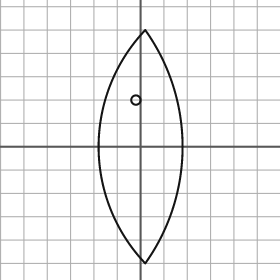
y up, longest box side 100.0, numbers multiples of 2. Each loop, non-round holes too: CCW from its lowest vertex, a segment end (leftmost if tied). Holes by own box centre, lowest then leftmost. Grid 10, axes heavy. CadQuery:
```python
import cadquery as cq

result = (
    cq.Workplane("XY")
    .moveTo(2.0, -50.0)
    .threePointArc((18.0, 0.0), (2.0, 50.0))
    .threePointArc((-18.0, 0.0), (2.0, -50.0))
    .close()
    .moveTo(-2.0, 20.0)
    .circle(2.0)
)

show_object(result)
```